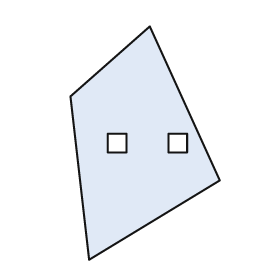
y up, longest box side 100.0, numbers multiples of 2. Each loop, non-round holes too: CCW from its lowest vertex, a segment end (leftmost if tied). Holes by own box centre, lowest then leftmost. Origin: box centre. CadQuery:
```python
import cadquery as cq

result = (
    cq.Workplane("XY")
    .moveTo(-24.0, -50.0)
    .lineTo(32.0, -16.0)
    .lineTo(2.0, 50.0)
    .lineTo(-32.0, 20.0)
    .close()
    .moveTo(-16.0, -4.0)
    .lineTo(-8.0, -4.0)
    .lineTo(-8.0, 4.0)
    .lineTo(-16.0, 4.0)
    .close()
    .moveTo(10.0, -4.0)
    .lineTo(18.0, -4.0)
    .lineTo(18.0, 4.0)
    .lineTo(10.0, 4.0)
    .close()
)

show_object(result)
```